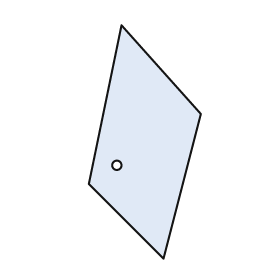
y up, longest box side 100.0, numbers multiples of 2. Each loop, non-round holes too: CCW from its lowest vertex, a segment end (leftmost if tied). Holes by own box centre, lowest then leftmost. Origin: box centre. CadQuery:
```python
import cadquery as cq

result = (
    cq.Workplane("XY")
    .moveTo(8.0, -50.0)
    .lineTo(24.0, 12.0)
    .lineTo(-10.0, 50.0)
    .lineTo(-24.0, -18.0)
    .close()
    .moveTo(-12.0, -10.0)
    .circle(2.0)
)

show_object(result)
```